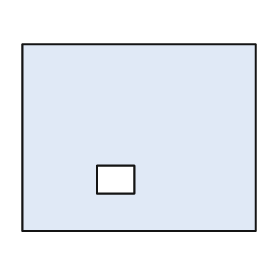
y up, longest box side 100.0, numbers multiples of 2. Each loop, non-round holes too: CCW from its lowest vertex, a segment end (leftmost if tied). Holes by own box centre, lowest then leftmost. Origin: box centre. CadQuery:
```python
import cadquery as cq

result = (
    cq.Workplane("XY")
    .moveTo(-50.0, -40.0)
    .lineTo(50.0, -40.0)
    .lineTo(50.0, 40.0)
    .lineTo(-50.0, 40.0)
    .close()
    .moveTo(-18.0, -24.0)
    .lineTo(-2.0, -24.0)
    .lineTo(-2.0, -12.0)
    .lineTo(-18.0, -12.0)
    .close()
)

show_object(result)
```